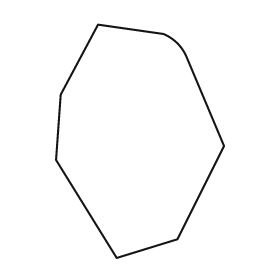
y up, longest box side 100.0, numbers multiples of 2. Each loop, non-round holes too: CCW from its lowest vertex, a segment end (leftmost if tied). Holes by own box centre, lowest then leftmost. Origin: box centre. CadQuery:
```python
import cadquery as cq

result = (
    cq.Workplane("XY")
    .moveTo(-10.0, -50.0)
    .lineTo(16.0, -42.0)
    .lineTo(36.0, -2.0)
    .lineTo(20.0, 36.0)
    .threePointArc((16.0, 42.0), (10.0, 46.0))
    .lineTo(-18.0, 50.0)
    .lineTo(-34.0, 20.0)
    .lineTo(-36.0, -8.0)
    .close()
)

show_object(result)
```